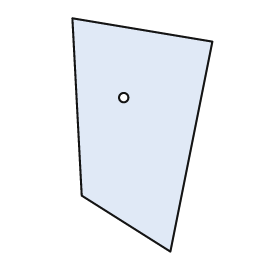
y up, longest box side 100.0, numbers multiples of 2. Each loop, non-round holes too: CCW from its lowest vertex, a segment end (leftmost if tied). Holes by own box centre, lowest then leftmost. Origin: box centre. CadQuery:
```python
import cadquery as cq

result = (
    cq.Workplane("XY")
    .moveTo(12.0, -50.0)
    .lineTo(30.0, 40.0)
    .lineTo(-30.0, 50.0)
    .lineTo(-26.0, -26.0)
    .close()
    .moveTo(-8.0, 16.0)
    .circle(2.0)
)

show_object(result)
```